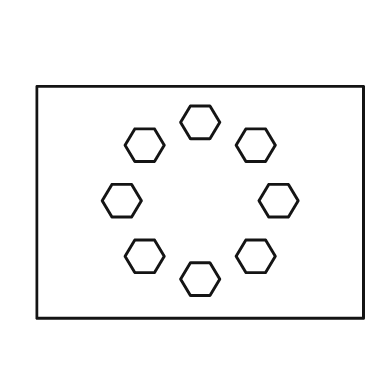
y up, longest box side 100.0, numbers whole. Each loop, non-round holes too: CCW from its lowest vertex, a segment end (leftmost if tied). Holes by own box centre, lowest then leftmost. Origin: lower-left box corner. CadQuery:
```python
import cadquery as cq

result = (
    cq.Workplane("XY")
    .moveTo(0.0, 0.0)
    .lineTo(100.0, 0.0)
    .lineTo(100.0, 71.0)
    .lineTo(0.0, 71.0)
    .close()
    .moveTo(47.0, 7.0)
    .lineTo(53.0, 7.0)
    .lineTo(56.0, 12.0)
    .lineTo(53.0, 17.0)
    .lineTo(47.0, 17.0)
    .lineTo(44.0, 12.0)
    .close()
    .moveTo(30.0, 14.0)
    .lineTo(36.0, 14.0)
    .lineTo(39.0, 19.0)
    .lineTo(36.0, 24.0)
    .lineTo(30.0, 24.0)
    .lineTo(27.0, 19.0)
    .close()
    .moveTo(64.0, 14.0)
    .lineTo(70.0, 14.0)
    .lineTo(73.0, 19.0)
    .lineTo(70.0, 24.0)
    .lineTo(64.0, 24.0)
    .lineTo(61.0, 19.0)
    .close()
    .moveTo(23.0, 31.0)
    .lineTo(29.0, 31.0)
    .lineTo(32.0, 36.0)
    .lineTo(29.0, 41.0)
    .lineTo(23.0, 41.0)
    .lineTo(20.0, 36.0)
    .close()
    .moveTo(71.0, 31.0)
    .lineTo(77.0, 31.0)
    .lineTo(80.0, 36.0)
    .lineTo(77.0, 41.0)
    .lineTo(71.0, 41.0)
    .lineTo(68.0, 36.0)
    .close()
    .moveTo(30.0, 48.0)
    .lineTo(36.0, 48.0)
    .lineTo(39.0, 53.0)
    .lineTo(36.0, 58.0)
    .lineTo(30.0, 58.0)
    .lineTo(27.0, 53.0)
    .close()
    .moveTo(64.0, 48.0)
    .lineTo(70.0, 48.0)
    .lineTo(73.0, 53.0)
    .lineTo(70.0, 58.0)
    .lineTo(64.0, 58.0)
    .lineTo(61.0, 53.0)
    .close()
    .moveTo(47.0, 55.0)
    .lineTo(53.0, 55.0)
    .lineTo(56.0, 60.0)
    .lineTo(53.0, 65.0)
    .lineTo(47.0, 65.0)
    .lineTo(44.0, 60.0)
    .close()
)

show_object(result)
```